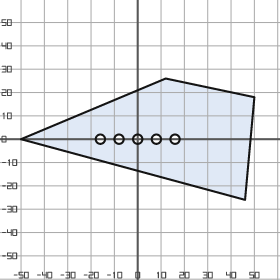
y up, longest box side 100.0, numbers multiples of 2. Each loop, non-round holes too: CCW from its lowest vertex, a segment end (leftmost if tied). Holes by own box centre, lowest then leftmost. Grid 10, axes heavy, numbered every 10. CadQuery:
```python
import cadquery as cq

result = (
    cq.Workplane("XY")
    .moveTo(46.0, -26.0)
    .lineTo(50.0, 18.0)
    .lineTo(12.0, 26.0)
    .lineTo(-50.0, 0.0)
    .close()
    .moveTo(-16.0, 0.0)
    .circle(2.0)
    .moveTo(-8.0, 0.0)
    .circle(2.0)
    .moveTo(0.0, 0.0)
    .circle(2.0)
    .moveTo(8.0, 0.0)
    .circle(2.0)
    .moveTo(16.0, 0.0)
    .circle(2.0)
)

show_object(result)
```